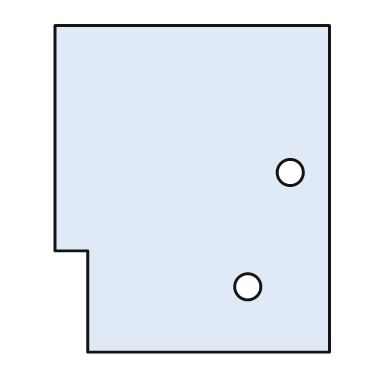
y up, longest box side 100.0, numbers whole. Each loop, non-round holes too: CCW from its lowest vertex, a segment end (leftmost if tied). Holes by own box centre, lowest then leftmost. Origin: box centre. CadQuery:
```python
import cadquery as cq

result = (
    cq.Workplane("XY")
    .moveTo(-32.0, -50.0)
    .lineTo(42.0, -50.0)
    .lineTo(42.0, 50.0)
    .lineTo(-42.0, 50.0)
    .lineTo(-42.0, -19.0)
    .lineTo(-32.0, -19.0)
    .close()
    .moveTo(17.0, -30.0)
    .circle(4.0)
    .moveTo(30.0, 5.0)
    .circle(4.0)
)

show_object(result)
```